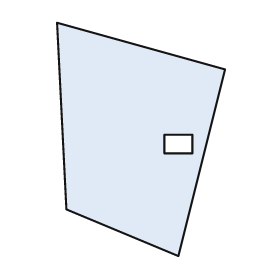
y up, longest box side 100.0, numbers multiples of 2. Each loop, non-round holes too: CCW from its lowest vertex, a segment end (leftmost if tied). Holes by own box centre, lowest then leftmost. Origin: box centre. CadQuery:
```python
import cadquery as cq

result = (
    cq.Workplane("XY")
    .moveTo(16.0, -50.0)
    .lineTo(36.0, 30.0)
    .lineTo(-36.0, 50.0)
    .lineTo(-32.0, -30.0)
    .close()
    .moveTo(10.0, -6.0)
    .lineTo(22.0, -6.0)
    .lineTo(22.0, 2.0)
    .lineTo(10.0, 2.0)
    .close()
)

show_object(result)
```